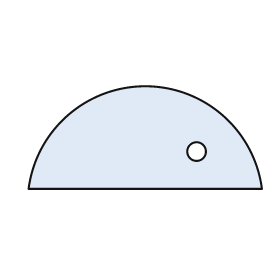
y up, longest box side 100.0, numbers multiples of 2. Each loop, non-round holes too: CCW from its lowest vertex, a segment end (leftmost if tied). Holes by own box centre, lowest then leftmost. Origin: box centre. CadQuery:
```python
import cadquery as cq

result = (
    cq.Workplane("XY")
    .moveTo(-50.0, -22.0)
    .lineTo(50.0, -22.0)
    .threePointArc((0.0, 22.0), (-50.0, -22.0))
    .close()
    .moveTo(22.0, -6.0)
    .circle(4.0)
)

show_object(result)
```